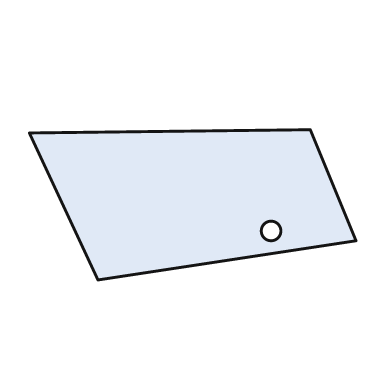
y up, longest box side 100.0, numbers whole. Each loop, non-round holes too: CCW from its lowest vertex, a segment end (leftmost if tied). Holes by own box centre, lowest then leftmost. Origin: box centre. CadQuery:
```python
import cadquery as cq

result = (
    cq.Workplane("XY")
    .moveTo(-29.0, -23.0)
    .lineTo(50.0, -11.0)
    .lineTo(36.0, 23.0)
    .lineTo(-50.0, 22.0)
    .close()
    .moveTo(24.0, -8.0)
    .circle(3.0)
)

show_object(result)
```